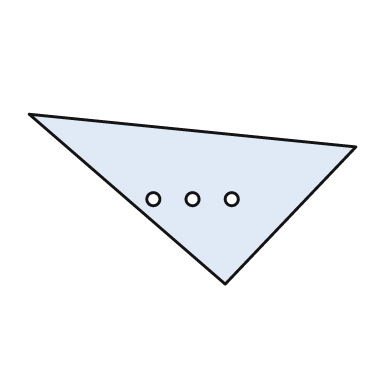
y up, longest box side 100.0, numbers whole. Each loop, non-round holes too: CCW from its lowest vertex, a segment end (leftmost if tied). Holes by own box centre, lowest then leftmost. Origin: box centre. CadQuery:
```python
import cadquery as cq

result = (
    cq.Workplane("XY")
    .moveTo(10.0, -26.0)
    .lineTo(50.0, 16.0)
    .lineTo(-50.0, 26.0)
    .close()
    .moveTo(-12.0, 0.0)
    .circle(2.0)
    .moveTo(0.0, 0.0)
    .circle(2.0)
    .moveTo(12.0, 0.0)
    .circle(2.0)
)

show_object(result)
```